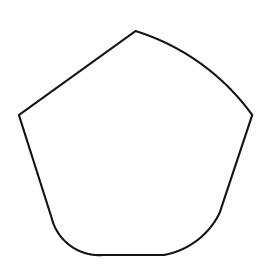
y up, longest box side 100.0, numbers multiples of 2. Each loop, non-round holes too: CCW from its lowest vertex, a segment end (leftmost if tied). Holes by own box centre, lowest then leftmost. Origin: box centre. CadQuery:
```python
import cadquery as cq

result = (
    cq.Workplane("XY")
    .moveTo(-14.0, -48.0)
    .lineTo(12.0, -48.0)
    .threePointArc((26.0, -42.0), (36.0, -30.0))
    .lineTo(50.0, 12.0)
    .threePointArc((28.0, 34.0), (0.0, 48.0))
    .lineTo(-50.0, 12.0)
    .lineTo(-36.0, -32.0)
    .threePointArc((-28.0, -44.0), (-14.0, -48.0))
    .close()
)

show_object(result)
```